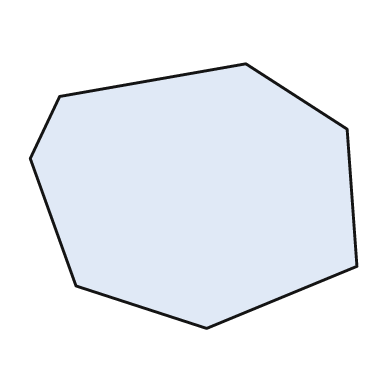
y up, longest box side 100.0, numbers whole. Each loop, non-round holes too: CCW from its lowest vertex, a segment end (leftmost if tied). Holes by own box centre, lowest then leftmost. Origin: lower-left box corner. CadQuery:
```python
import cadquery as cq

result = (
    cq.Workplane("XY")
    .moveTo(54.0, 0.0)
    .lineTo(100.0, 19.0)
    .lineTo(97.0, 61.0)
    .lineTo(66.0, 81.0)
    .lineTo(9.0, 71.0)
    .lineTo(0.0, 52.0)
    .lineTo(14.0, 13.0)
    .close()
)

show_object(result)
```